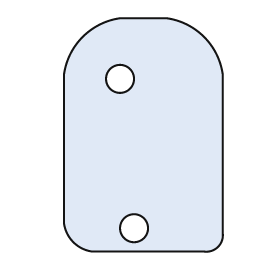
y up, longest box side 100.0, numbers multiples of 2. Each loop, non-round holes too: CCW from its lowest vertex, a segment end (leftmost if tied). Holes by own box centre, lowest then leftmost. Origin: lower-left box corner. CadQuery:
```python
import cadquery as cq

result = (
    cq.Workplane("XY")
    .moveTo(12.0, 0.0)
    .lineTo(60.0, 0.0)
    .threePointArc((66.0, 2.0), (68.0, 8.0))
    .lineTo(68.0, 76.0)
    .threePointArc((60.0, 92.0), (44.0, 100.0))
    .lineTo(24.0, 100.0)
    .threePointArc((8.0, 92.0), (0.0, 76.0))
    .lineTo(0.0, 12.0)
    .threePointArc((4.0, 4.0), (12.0, 0.0))
    .close()
    .moveTo(30.0, 10.0)
    .circle(6.0)
    .moveTo(24.0, 74.0)
    .circle(6.0)
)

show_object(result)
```